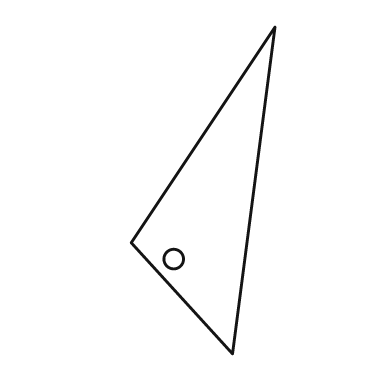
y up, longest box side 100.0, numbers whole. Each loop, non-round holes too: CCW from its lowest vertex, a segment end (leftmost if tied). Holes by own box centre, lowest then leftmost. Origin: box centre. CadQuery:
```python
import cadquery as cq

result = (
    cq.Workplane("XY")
    .moveTo(9.0, -50.0)
    .lineTo(22.0, 50.0)
    .lineTo(-22.0, -16.0)
    .close()
    .moveTo(-9.0, -21.0)
    .circle(3.0)
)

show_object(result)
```